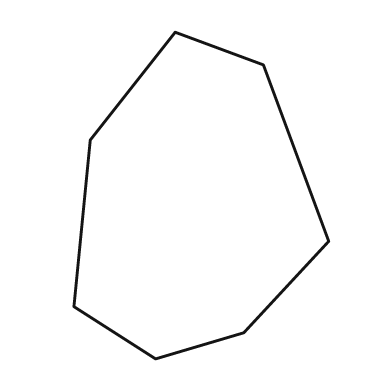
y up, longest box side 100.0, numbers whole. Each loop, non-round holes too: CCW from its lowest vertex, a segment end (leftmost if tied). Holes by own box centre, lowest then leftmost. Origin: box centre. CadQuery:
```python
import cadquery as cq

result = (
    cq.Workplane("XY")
    .moveTo(-14.0, -50.0)
    .lineTo(13.0, -42.0)
    .lineTo(39.0, -14.0)
    .lineTo(19.0, 40.0)
    .lineTo(-8.0, 50.0)
    .lineTo(-34.0, 17.0)
    .lineTo(-39.0, -34.0)
    .close()
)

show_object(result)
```